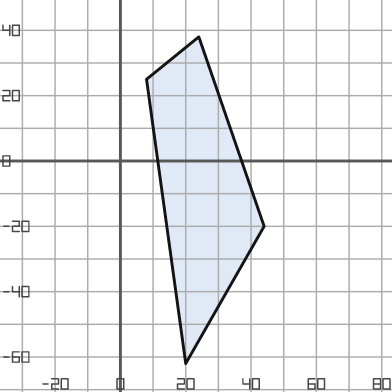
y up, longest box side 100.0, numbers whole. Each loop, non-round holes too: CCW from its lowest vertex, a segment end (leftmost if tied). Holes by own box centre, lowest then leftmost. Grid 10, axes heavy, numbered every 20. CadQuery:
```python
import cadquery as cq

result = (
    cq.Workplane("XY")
    .moveTo(20.0, -62.0)
    .lineTo(44.0, -20.0)
    .lineTo(24.0, 38.0)
    .lineTo(8.0, 25.0)
    .close()
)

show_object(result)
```